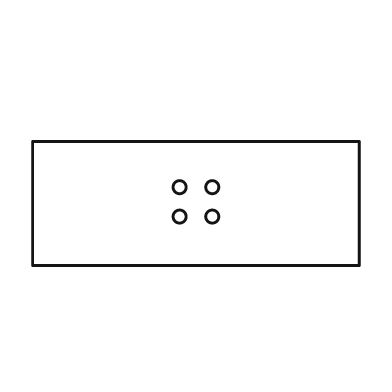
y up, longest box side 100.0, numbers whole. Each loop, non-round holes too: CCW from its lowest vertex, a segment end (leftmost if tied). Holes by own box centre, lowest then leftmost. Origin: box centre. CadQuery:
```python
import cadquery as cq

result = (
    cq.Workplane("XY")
    .moveTo(-50.0, -19.0)
    .lineTo(50.0, -19.0)
    .lineTo(50.0, 19.0)
    .lineTo(-50.0, 19.0)
    .close()
    .moveTo(-5.0, -4.0)
    .circle(2.0)
    .moveTo(5.0, -4.0)
    .circle(2.0)
    .moveTo(-5.0, 5.0)
    .circle(2.0)
    .moveTo(5.0, 5.0)
    .circle(2.0)
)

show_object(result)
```